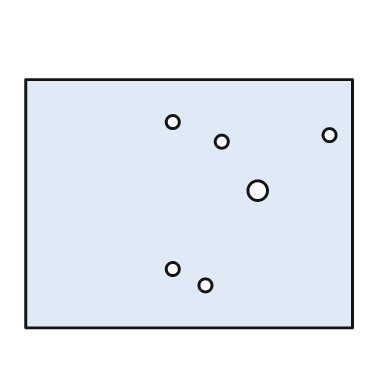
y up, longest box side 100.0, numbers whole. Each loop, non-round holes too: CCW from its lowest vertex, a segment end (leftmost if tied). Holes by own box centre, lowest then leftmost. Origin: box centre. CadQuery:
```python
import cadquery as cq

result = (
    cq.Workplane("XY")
    .moveTo(-50.0, -38.0)
    .lineTo(50.0, -38.0)
    .lineTo(50.0, 38.0)
    .lineTo(-50.0, 38.0)
    .close()
    .moveTo(5.0, -25.0)
    .circle(2.0)
    .moveTo(-5.0, -20.0)
    .circle(2.0)
    .moveTo(21.0, 4.0)
    .circle(3.0)
    .moveTo(10.0, 19.0)
    .circle(2.0)
    .moveTo(43.0, 21.0)
    .circle(2.0)
    .moveTo(-5.0, 25.0)
    .circle(2.0)
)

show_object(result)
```